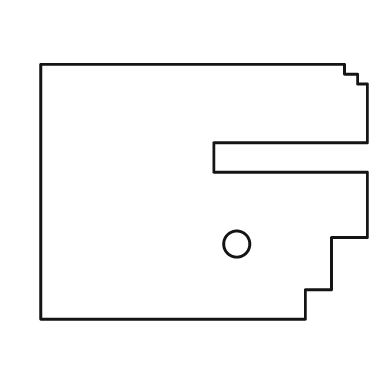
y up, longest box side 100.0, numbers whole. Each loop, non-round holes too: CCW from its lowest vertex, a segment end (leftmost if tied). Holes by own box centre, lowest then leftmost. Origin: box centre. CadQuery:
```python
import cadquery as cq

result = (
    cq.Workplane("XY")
    .moveTo(-50.0, -39.0)
    .lineTo(31.0, -39.0)
    .lineTo(31.0, -30.0)
    .lineTo(39.0, -30.0)
    .lineTo(39.0, -14.0)
    .lineTo(50.0, -14.0)
    .lineTo(50.0, 6.0)
    .lineTo(3.0, 6.0)
    .lineTo(3.0, 15.0)
    .lineTo(50.0, 15.0)
    .lineTo(50.0, 33.0)
    .lineTo(47.0, 33.0)
    .lineTo(47.0, 36.0)
    .lineTo(43.0, 36.0)
    .lineTo(43.0, 39.0)
    .lineTo(-50.0, 39.0)
    .close()
    .moveTo(10.0, -16.0)
    .circle(4.0)
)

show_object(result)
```